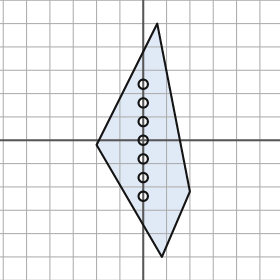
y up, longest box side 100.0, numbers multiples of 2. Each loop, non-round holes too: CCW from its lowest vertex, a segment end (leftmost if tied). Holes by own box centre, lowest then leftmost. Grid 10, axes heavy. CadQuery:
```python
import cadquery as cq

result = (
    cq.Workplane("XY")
    .moveTo(8.0, -50.0)
    .lineTo(20.0, -22.0)
    .lineTo(6.0, 50.0)
    .lineTo(-20.0, -2.0)
    .close()
    .moveTo(0.0, -24.0)
    .circle(2.0)
    .moveTo(0.0, -16.0)
    .circle(2.0)
    .moveTo(0.0, -8.0)
    .circle(2.0)
    .moveTo(0.0, 0.0)
    .circle(2.0)
    .moveTo(0.0, 8.0)
    .circle(2.0)
    .moveTo(0.0, 16.0)
    .circle(2.0)
    .moveTo(0.0, 24.0)
    .circle(2.0)
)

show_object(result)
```